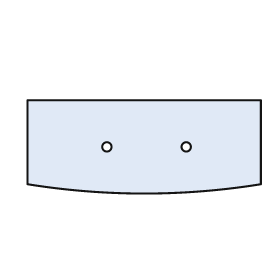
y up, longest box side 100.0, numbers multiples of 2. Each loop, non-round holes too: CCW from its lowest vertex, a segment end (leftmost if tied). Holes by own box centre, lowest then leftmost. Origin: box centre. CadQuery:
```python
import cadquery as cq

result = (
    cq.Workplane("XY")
    .moveTo(-50.0, -16.0)
    .threePointArc((0.0, -20.0), (50.0, -16.0))
    .lineTo(50.0, 20.0)
    .lineTo(-50.0, 20.0)
    .close()
    .moveTo(-16.0, 0.0)
    .circle(2.0)
    .moveTo(18.0, 0.0)
    .circle(2.0)
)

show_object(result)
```